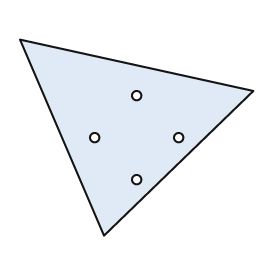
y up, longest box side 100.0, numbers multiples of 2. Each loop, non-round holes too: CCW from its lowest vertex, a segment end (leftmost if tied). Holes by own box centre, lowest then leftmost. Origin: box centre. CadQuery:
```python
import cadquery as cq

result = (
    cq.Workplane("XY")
    .moveTo(-14.0, -42.0)
    .lineTo(50.0, 20.0)
    .lineTo(-50.0, 42.0)
    .close()
    .moveTo(0.0, -18.0)
    .circle(2.0)
    .moveTo(-18.0, 0.0)
    .circle(2.0)
    .moveTo(18.0, 0.0)
    .circle(2.0)
    .moveTo(0.0, 18.0)
    .circle(2.0)
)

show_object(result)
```